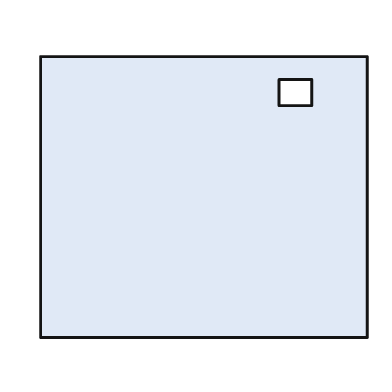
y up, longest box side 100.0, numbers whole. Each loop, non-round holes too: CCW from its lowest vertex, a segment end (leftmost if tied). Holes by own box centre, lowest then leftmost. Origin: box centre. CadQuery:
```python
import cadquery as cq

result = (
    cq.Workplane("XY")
    .moveTo(-50.0, -43.0)
    .lineTo(50.0, -43.0)
    .lineTo(50.0, 43.0)
    .lineTo(-50.0, 43.0)
    .close()
    .moveTo(23.0, 28.0)
    .lineTo(33.0, 28.0)
    .lineTo(33.0, 36.0)
    .lineTo(23.0, 36.0)
    .close()
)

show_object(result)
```